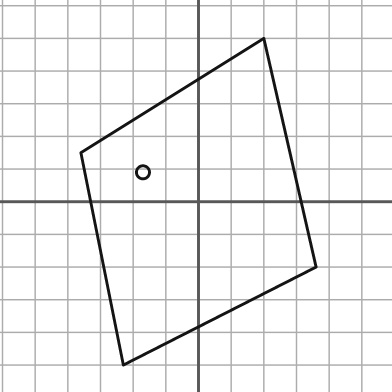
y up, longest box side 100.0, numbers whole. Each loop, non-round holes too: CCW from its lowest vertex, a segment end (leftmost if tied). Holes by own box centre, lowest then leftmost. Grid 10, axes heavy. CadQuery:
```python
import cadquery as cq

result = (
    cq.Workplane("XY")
    .moveTo(-23.0, -50.0)
    .lineTo(36.0, -20.0)
    .lineTo(20.0, 50.0)
    .lineTo(-36.0, 15.0)
    .close()
    .moveTo(-17.0, 9.0)
    .circle(2.0)
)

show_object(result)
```